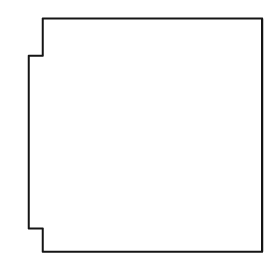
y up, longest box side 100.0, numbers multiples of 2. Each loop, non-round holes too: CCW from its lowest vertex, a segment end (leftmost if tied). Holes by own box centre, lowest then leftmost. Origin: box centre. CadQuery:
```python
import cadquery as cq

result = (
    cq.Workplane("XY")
    .moveTo(-44.0, -50.0)
    .lineTo(50.0, -50.0)
    .lineTo(50.0, 50.0)
    .lineTo(-44.0, 50.0)
    .lineTo(-44.0, 34.0)
    .lineTo(-50.0, 34.0)
    .lineTo(-50.0, -40.0)
    .lineTo(-44.0, -40.0)
    .close()
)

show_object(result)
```